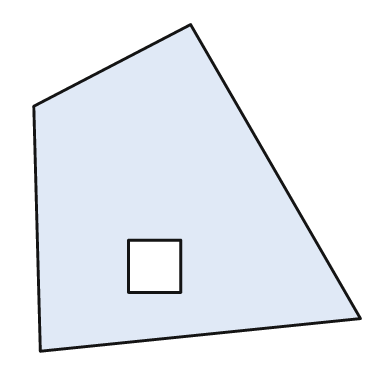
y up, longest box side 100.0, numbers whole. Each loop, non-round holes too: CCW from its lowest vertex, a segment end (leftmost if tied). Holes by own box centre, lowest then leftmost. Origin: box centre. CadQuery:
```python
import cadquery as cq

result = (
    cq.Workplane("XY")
    .moveTo(-48.0, -50.0)
    .lineTo(50.0, -40.0)
    .lineTo(-2.0, 50.0)
    .lineTo(-50.0, 25.0)
    .close()
    .moveTo(-21.0, -32.0)
    .lineTo(-5.0, -32.0)
    .lineTo(-5.0, -16.0)
    .lineTo(-21.0, -16.0)
    .close()
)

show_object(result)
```